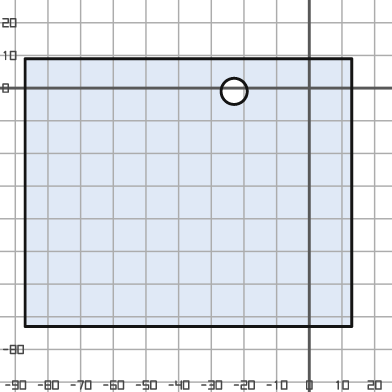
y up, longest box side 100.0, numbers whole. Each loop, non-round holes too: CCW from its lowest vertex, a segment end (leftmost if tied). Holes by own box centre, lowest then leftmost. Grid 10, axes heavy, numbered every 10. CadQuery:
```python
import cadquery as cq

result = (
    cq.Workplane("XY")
    .moveTo(-87.0, -73.0)
    .lineTo(13.0, -73.0)
    .lineTo(13.0, 9.0)
    .lineTo(-87.0, 9.0)
    .close()
    .moveTo(-23.0, -1.0)
    .circle(4.0)
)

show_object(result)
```